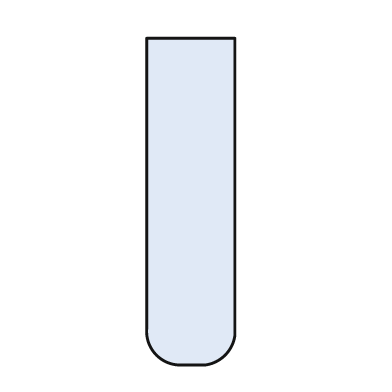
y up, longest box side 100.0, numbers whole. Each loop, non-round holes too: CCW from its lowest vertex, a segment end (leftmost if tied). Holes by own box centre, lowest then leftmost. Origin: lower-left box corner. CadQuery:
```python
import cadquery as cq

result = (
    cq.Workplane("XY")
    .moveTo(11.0, 0.0)
    .lineTo(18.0, 0.0)
    .threePointArc((24.0, 3.0), (27.0, 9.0))
    .lineTo(27.0, 100.0)
    .lineTo(0.0, 100.0)
    .lineTo(0.0, 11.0)
    .threePointArc((3.0, 3.0), (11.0, 0.0))
    .close()
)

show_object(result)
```